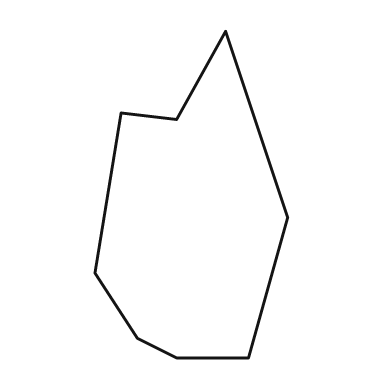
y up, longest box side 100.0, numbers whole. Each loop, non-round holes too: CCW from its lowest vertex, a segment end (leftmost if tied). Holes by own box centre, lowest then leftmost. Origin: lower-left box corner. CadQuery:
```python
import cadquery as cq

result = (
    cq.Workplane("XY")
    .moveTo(25.0, 0.0)
    .lineTo(47.0, 0.0)
    .lineTo(59.0, 43.0)
    .lineTo(40.0, 100.0)
    .lineTo(25.0, 73.0)
    .lineTo(8.0, 75.0)
    .lineTo(0.0, 26.0)
    .lineTo(13.0, 6.0)
    .close()
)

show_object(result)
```